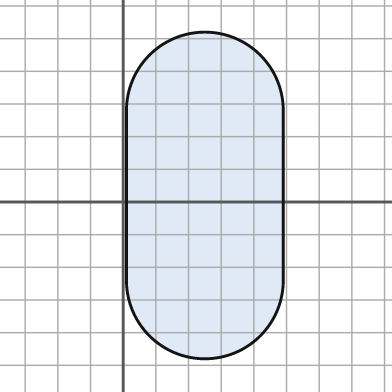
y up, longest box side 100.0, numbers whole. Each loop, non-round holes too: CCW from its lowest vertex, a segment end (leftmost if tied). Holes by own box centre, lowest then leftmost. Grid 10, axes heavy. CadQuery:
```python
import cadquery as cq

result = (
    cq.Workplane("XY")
    .moveTo(1.0, -24.0)
    .threePointArc((25.0, -48.0), (49.0, -24.0))
    .lineTo(49.0, 28.0)
    .threePointArc((25.0, 52.0), (1.0, 28.0))
    .close()
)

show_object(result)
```